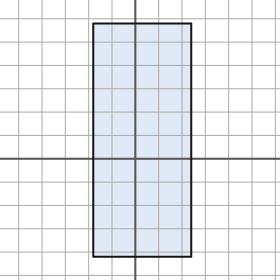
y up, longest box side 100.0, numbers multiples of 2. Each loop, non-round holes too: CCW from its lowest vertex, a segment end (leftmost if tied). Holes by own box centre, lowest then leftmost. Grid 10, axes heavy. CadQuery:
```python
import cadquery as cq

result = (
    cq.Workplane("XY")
    .moveTo(-18.0, -42.0)
    .lineTo(24.0, -42.0)
    .lineTo(24.0, 58.0)
    .lineTo(-18.0, 58.0)
    .close()
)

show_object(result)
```